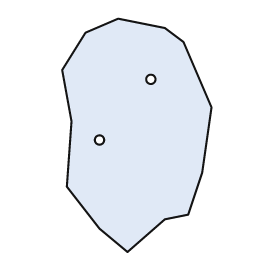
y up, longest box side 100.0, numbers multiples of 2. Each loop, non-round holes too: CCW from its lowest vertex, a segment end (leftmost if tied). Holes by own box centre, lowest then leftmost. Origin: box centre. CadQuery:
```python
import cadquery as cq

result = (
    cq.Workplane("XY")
    .moveTo(-4.0, -50.0)
    .lineTo(12.0, -36.0)
    .lineTo(22.0, -34.0)
    .lineTo(28.0, -16.0)
    .lineTo(32.0, 12.0)
    .lineTo(20.0, 40.0)
    .lineTo(12.0, 46.0)
    .lineTo(-8.0, 50.0)
    .lineTo(-22.0, 44.0)
    .lineTo(-32.0, 28.0)
    .lineTo(-28.0, 6.0)
    .lineTo(-30.0, -22.0)
    .lineTo(-16.0, -40.0)
    .close()
    .moveTo(-16.0, -2.0)
    .circle(2.0)
    .moveTo(6.0, 24.0)
    .circle(2.0)
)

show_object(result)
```